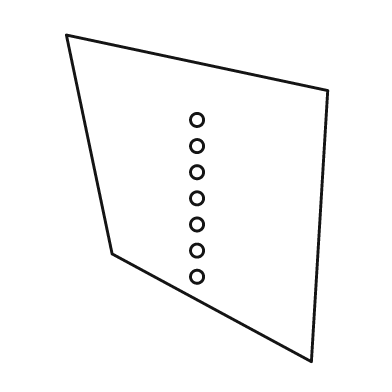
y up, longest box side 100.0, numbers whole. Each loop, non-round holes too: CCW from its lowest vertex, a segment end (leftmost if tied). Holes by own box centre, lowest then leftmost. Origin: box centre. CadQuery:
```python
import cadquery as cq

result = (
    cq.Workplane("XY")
    .moveTo(35.0, -50.0)
    .lineTo(40.0, 33.0)
    .lineTo(-40.0, 50.0)
    .lineTo(-26.0, -17.0)
    .close()
    .moveTo(0.0, -24.0)
    .circle(2.0)
    .moveTo(0.0, -16.0)
    .circle(2.0)
    .moveTo(0.0, -8.0)
    .circle(2.0)
    .moveTo(0.0, 0.0)
    .circle(2.0)
    .moveTo(0.0, 8.0)
    .circle(2.0)
    .moveTo(0.0, 16.0)
    .circle(2.0)
    .moveTo(0.0, 24.0)
    .circle(2.0)
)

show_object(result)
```